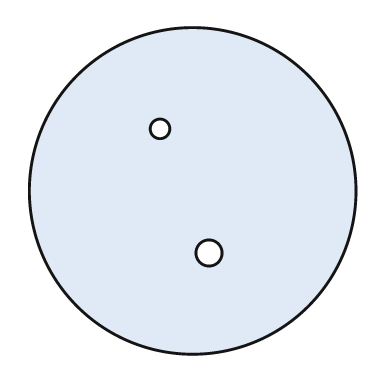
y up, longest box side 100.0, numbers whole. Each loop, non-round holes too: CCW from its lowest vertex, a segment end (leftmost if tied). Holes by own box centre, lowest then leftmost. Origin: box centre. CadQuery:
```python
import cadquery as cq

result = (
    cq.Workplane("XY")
    .moveTo(0.0, 0.0)
    .circle(50.0)
    .moveTo(5.0, -19.0)
    .circle(4.0)
    .moveTo(-10.0, 19.0)
    .circle(3.0)
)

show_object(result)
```